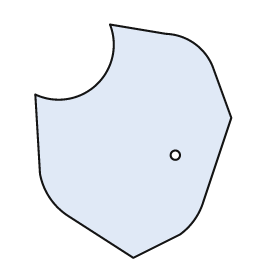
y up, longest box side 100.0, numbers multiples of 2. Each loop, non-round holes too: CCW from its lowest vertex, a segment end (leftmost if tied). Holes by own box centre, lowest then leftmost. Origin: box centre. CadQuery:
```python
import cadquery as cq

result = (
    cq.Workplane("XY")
    .moveTo(0.0, -50.0)
    .lineTo(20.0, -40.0)
    .threePointArc((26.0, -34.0), (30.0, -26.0))
    .lineTo(42.0, 10.0)
    .lineTo(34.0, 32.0)
    .threePointArc((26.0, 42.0), (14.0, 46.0))
    .lineTo(-10.0, 50.0)
    .threePointArc((-16.0, 24.0), (-42.0, 20.0))
    .lineTo(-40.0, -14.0)
    .threePointArc((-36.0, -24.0), (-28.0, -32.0))
    .close()
    .moveTo(18.0, -6.0)
    .circle(2.0)
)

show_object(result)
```